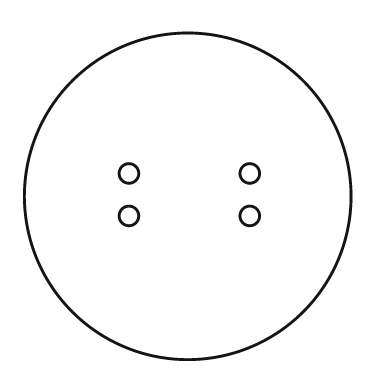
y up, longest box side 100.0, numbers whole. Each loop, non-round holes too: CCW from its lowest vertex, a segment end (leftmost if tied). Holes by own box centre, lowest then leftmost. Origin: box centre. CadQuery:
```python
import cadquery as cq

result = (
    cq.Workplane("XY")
    .moveTo(0.0, 0.0)
    .circle(50.0)
    .moveTo(-18.0, -6.0)
    .circle(3.0)
    .moveTo(19.0, -6.0)
    .circle(3.0)
    .moveTo(-18.0, 7.0)
    .circle(3.0)
    .moveTo(19.0, 7.0)
    .circle(3.0)
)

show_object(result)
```